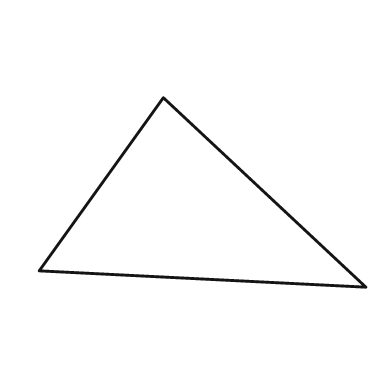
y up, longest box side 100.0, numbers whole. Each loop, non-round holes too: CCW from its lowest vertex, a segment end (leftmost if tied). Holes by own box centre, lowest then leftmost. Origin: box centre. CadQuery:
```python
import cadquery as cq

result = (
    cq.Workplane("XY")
    .moveTo(50.0, -29.0)
    .lineTo(-12.0, 29.0)
    .lineTo(-50.0, -24.0)
    .close()
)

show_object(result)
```